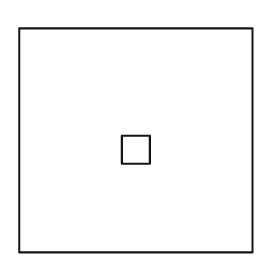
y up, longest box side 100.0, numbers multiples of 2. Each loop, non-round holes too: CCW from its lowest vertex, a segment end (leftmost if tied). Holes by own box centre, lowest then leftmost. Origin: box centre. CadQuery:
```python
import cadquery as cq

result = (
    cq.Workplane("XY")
    .moveTo(-50.0, -48.0)
    .lineTo(50.0, -48.0)
    .lineTo(50.0, 48.0)
    .lineTo(-50.0, 48.0)
    .close()
    .moveTo(-6.0, -10.0)
    .lineTo(6.0, -10.0)
    .lineTo(6.0, 2.0)
    .lineTo(-6.0, 2.0)
    .close()
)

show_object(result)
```